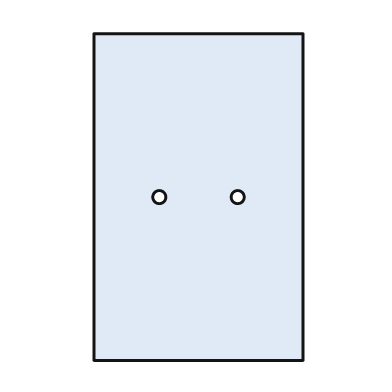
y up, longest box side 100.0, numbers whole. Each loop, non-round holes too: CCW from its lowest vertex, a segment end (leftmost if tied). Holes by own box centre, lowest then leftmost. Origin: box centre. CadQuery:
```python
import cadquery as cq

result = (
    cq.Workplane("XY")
    .moveTo(-32.0, -50.0)
    .lineTo(32.0, -50.0)
    .lineTo(32.0, 50.0)
    .lineTo(-32.0, 50.0)
    .close()
    .moveTo(-12.0, 0.0)
    .circle(2.0)
    .moveTo(12.0, 0.0)
    .circle(2.0)
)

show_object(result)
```